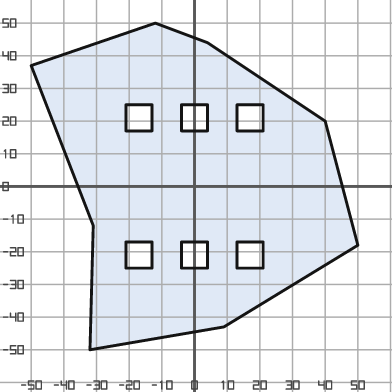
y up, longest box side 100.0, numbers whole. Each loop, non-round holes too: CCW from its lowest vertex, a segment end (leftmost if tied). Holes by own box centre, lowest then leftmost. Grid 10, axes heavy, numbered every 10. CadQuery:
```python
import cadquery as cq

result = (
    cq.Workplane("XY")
    .moveTo(-32.0, -50.0)
    .lineTo(9.0, -43.0)
    .lineTo(50.0, -18.0)
    .lineTo(40.0, 20.0)
    .lineTo(4.0, 44.0)
    .lineTo(-12.0, 50.0)
    .lineTo(-50.0, 37.0)
    .lineTo(-31.0, -12.0)
    .close()
    .moveTo(-21.0, -25.0)
    .lineTo(-13.0, -25.0)
    .lineTo(-13.0, -17.0)
    .lineTo(-21.0, -17.0)
    .close()
    .moveTo(-4.0, -25.0)
    .lineTo(4.0, -25.0)
    .lineTo(4.0, -17.0)
    .lineTo(-4.0, -17.0)
    .close()
    .moveTo(13.0, -25.0)
    .lineTo(21.0, -25.0)
    .lineTo(21.0, -17.0)
    .lineTo(13.0, -17.0)
    .close()
    .moveTo(-21.0, 17.0)
    .lineTo(-13.0, 17.0)
    .lineTo(-13.0, 25.0)
    .lineTo(-21.0, 25.0)
    .close()
    .moveTo(-4.0, 17.0)
    .lineTo(4.0, 17.0)
    .lineTo(4.0, 25.0)
    .lineTo(-4.0, 25.0)
    .close()
    .moveTo(13.0, 17.0)
    .lineTo(21.0, 17.0)
    .lineTo(21.0, 25.0)
    .lineTo(13.0, 25.0)
    .close()
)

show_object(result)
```